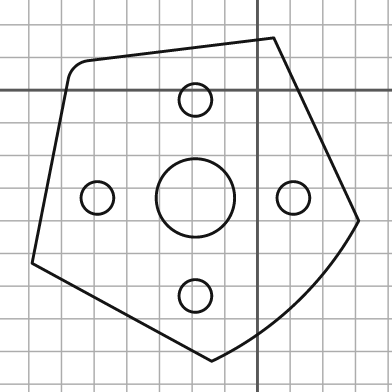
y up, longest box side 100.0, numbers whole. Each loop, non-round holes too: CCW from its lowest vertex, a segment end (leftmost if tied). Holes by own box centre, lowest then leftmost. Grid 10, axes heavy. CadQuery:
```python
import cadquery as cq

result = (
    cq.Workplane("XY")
    .moveTo(-14.0, -83.0)
    .threePointArc((12.0, -65.0), (31.0, -40.0))
    .lineTo(5.0, 16.0)
    .lineTo(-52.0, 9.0)
    .threePointArc((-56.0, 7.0), (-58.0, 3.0))
    .lineTo(-69.0, -53.0)
    .close()
    .moveTo(-19.0, -63.0)
    .circle(5.0)
    .moveTo(-49.0, -33.0)
    .circle(5.0)
    .moveTo(-19.0, -33.0)
    .circle(12.0)
    .moveTo(11.0, -33.0)
    .circle(5.0)
    .moveTo(-19.0, -3.0)
    .circle(5.0)
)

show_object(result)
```